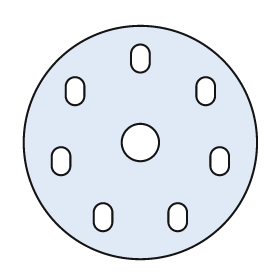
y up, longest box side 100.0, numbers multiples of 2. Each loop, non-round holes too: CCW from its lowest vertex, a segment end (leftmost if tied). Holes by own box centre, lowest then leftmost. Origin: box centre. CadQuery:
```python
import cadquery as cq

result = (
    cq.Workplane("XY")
    .moveTo(0.0, 0.0)
    .circle(50.0)
    .moveTo(-20.0, -34.0)
    .threePointArc((-16.0, -38.0), (-12.0, -34.0))
    .lineTo(-12.0, -30.0)
    .threePointArc((-16.0, -26.0), (-20.0, -30.0))
    .close()
    .moveTo(12.0, -34.0)
    .threePointArc((16.0, -38.0), (20.0, -34.0))
    .lineTo(20.0, -30.0)
    .threePointArc((16.0, -26.0), (12.0, -30.0))
    .close()
    .moveTo(-38.0, -10.0)
    .threePointArc((-34.0, -14.0), (-30.0, -10.0))
    .lineTo(-30.0, -6.0)
    .threePointArc((-34.0, -2.0), (-38.0, -6.0))
    .close()
    .moveTo(30.0, -10.0)
    .threePointArc((34.0, -14.0), (38.0, -10.0))
    .lineTo(38.0, -6.0)
    .threePointArc((34.0, -2.0), (30.0, -6.0))
    .close()
    .moveTo(0.0, 0.0)
    .circle(8.0)
    .moveTo(-32.0, 20.0)
    .threePointArc((-28.0, 16.0), (-24.0, 20.0))
    .lineTo(-24.0, 24.0)
    .threePointArc((-28.0, 28.0), (-32.0, 24.0))
    .close()
    .moveTo(24.0, 20.0)
    .threePointArc((28.0, 16.0), (32.0, 20.0))
    .lineTo(32.0, 24.0)
    .threePointArc((28.0, 28.0), (24.0, 24.0))
    .close()
    .moveTo(-4.0, 34.0)
    .threePointArc((0.0, 30.0), (4.0, 34.0))
    .lineTo(4.0, 38.0)
    .threePointArc((0.0, 42.0), (-4.0, 38.0))
    .close()
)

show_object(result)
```